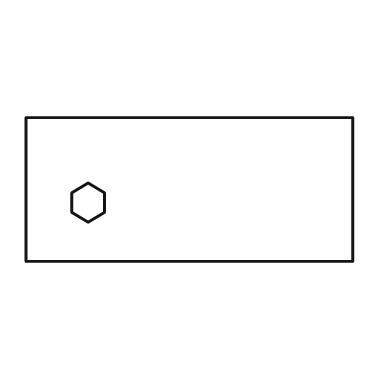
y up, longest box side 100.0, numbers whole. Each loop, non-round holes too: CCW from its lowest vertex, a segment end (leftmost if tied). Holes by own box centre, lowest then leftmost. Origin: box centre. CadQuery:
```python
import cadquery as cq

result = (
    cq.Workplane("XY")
    .moveTo(-50.0, -22.0)
    .lineTo(50.0, -22.0)
    .lineTo(50.0, 22.0)
    .lineTo(-50.0, 22.0)
    .close()
    .moveTo(-31.0, -10.0)
    .lineTo(-26.0, -7.0)
    .lineTo(-26.0, -1.0)
    .lineTo(-31.0, 2.0)
    .lineTo(-36.0, -1.0)
    .lineTo(-36.0, -7.0)
    .close()
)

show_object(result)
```